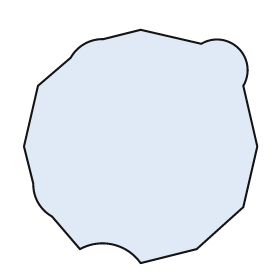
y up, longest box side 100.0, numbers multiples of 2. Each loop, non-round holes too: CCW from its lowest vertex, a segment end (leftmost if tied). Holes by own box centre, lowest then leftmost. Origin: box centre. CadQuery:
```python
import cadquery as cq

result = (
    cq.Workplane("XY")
    .moveTo(0.0, -50.0)
    .lineTo(24.0, -44.0)
    .lineTo(44.0, -26.0)
    .lineTo(50.0, 0.0)
    .lineTo(44.0, 26.0)
    .threePointArc((42.0, 42.0), (26.0, 44.0))
    .lineTo(0.0, 50.0)
    .lineTo(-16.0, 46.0)
    .threePointArc((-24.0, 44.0), (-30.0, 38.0))
    .lineTo(-44.0, 26.0)
    .lineTo(-50.0, 0.0)
    .lineTo(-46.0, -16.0)
    .threePointArc((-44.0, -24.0), (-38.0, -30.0))
    .lineTo(-26.0, -44.0)
    .threePointArc((-12.0, -42.0), (0.0, -50.0))
    .close()
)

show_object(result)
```